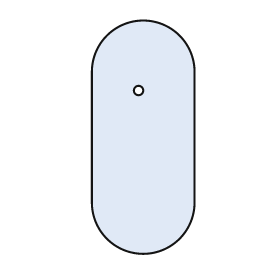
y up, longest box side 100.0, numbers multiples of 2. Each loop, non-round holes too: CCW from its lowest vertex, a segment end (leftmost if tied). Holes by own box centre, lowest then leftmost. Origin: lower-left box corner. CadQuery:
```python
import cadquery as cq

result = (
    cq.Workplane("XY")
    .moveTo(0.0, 22.0)
    .threePointArc((22.0, 0.0), (44.0, 22.0))
    .lineTo(44.0, 78.0)
    .threePointArc((22.0, 100.0), (0.0, 78.0))
    .close()
    .moveTo(20.0, 70.0)
    .circle(2.0)
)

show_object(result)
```